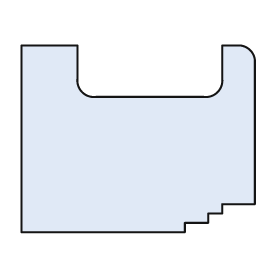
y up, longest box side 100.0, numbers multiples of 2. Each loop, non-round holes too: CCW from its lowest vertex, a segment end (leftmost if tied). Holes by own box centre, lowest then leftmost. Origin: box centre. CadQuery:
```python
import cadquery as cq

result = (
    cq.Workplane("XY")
    .moveTo(-50.0, -40.0)
    .lineTo(20.0, -40.0)
    .lineTo(20.0, -36.0)
    .lineTo(30.0, -36.0)
    .lineTo(30.0, -32.0)
    .lineTo(36.0, -32.0)
    .lineTo(36.0, -28.0)
    .lineTo(50.0, -28.0)
    .lineTo(50.0, 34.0)
    .threePointArc((48.0, 38.0), (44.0, 40.0))
    .lineTo(36.0, 40.0)
    .lineTo(36.0, 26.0)
    .threePointArc((34.0, 20.0), (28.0, 18.0))
    .lineTo(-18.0, 18.0)
    .threePointArc((-24.0, 20.0), (-26.0, 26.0))
    .lineTo(-26.0, 40.0)
    .lineTo(-50.0, 40.0)
    .close()
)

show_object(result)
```